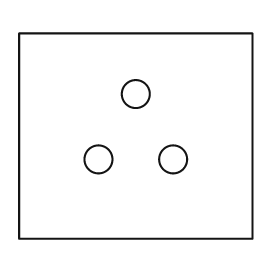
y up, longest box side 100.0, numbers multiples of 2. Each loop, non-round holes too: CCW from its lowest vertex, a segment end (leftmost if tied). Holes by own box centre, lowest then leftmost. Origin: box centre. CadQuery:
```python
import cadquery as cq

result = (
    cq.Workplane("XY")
    .moveTo(-50.0, -44.0)
    .lineTo(50.0, -44.0)
    .lineTo(50.0, 44.0)
    .lineTo(-50.0, 44.0)
    .close()
    .moveTo(-16.0, -10.0)
    .circle(6.0)
    .moveTo(16.0, -10.0)
    .circle(6.0)
    .moveTo(0.0, 18.0)
    .circle(6.0)
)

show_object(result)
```